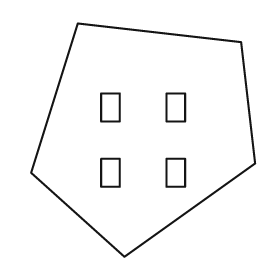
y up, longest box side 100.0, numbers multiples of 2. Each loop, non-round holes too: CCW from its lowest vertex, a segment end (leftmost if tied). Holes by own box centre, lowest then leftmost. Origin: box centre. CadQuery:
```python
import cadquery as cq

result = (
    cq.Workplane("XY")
    .moveTo(-8.0, -50.0)
    .lineTo(48.0, -10.0)
    .lineTo(42.0, 42.0)
    .lineTo(-28.0, 50.0)
    .lineTo(-48.0, -14.0)
    .close()
    .moveTo(-18.0, -20.0)
    .lineTo(-10.0, -20.0)
    .lineTo(-10.0, -8.0)
    .lineTo(-18.0, -8.0)
    .close()
    .moveTo(10.0, -20.0)
    .lineTo(18.0, -20.0)
    .lineTo(18.0, -8.0)
    .lineTo(10.0, -8.0)
    .close()
    .moveTo(-18.0, 8.0)
    .lineTo(-10.0, 8.0)
    .lineTo(-10.0, 20.0)
    .lineTo(-18.0, 20.0)
    .close()
    .moveTo(10.0, 8.0)
    .lineTo(18.0, 8.0)
    .lineTo(18.0, 20.0)
    .lineTo(10.0, 20.0)
    .close()
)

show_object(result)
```